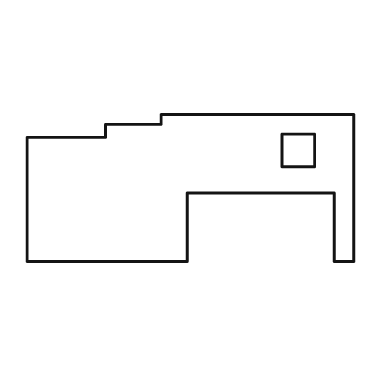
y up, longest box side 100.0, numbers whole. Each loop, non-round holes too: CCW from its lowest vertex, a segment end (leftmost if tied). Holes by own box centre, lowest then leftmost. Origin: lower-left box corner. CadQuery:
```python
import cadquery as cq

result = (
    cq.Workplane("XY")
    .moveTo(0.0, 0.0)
    .lineTo(49.0, 0.0)
    .lineTo(49.0, 21.0)
    .lineTo(94.0, 21.0)
    .lineTo(94.0, 0.0)
    .lineTo(100.0, 0.0)
    .lineTo(100.0, 45.0)
    .lineTo(41.0, 45.0)
    .lineTo(41.0, 42.0)
    .lineTo(24.0, 42.0)
    .lineTo(24.0, 38.0)
    .lineTo(0.0, 38.0)
    .close()
    .moveTo(78.0, 29.0)
    .lineTo(88.0, 29.0)
    .lineTo(88.0, 39.0)
    .lineTo(78.0, 39.0)
    .close()
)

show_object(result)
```